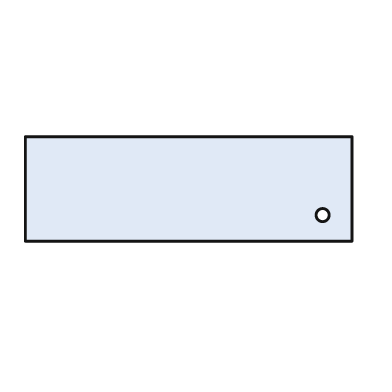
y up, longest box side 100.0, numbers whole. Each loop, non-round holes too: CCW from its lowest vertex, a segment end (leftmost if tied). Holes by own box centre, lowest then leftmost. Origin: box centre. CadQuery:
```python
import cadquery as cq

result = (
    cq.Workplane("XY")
    .moveTo(-50.0, -16.0)
    .lineTo(50.0, -16.0)
    .lineTo(50.0, 16.0)
    .lineTo(-50.0, 16.0)
    .close()
    .moveTo(41.0, -8.0)
    .circle(2.0)
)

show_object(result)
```